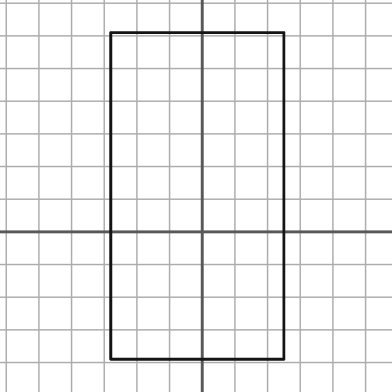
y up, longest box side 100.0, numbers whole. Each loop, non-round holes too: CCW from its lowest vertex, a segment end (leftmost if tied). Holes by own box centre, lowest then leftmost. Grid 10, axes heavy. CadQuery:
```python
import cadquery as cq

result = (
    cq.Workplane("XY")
    .moveTo(-28.0, -39.0)
    .lineTo(25.0, -39.0)
    .lineTo(25.0, 61.0)
    .lineTo(-28.0, 61.0)
    .close()
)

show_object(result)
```